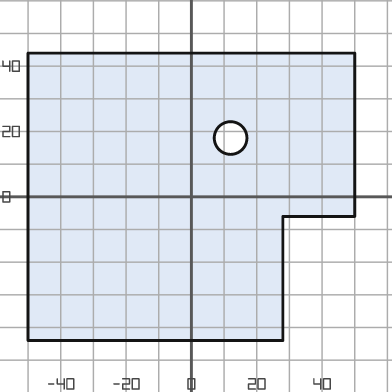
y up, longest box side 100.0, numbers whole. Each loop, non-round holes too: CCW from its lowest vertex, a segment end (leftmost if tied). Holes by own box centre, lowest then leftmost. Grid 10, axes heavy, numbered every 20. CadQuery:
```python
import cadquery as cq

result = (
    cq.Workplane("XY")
    .moveTo(-50.0, -44.0)
    .lineTo(28.0, -44.0)
    .lineTo(28.0, -6.0)
    .lineTo(50.0, -6.0)
    .lineTo(50.0, 44.0)
    .lineTo(-50.0, 44.0)
    .close()
    .moveTo(12.0, 18.0)
    .circle(5.0)
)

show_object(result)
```